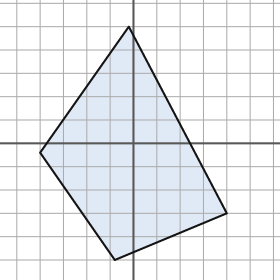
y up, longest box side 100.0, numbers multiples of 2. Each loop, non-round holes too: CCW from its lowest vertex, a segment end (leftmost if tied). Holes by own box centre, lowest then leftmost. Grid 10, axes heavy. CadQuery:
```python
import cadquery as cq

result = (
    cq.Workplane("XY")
    .moveTo(-8.0, -50.0)
    .lineTo(40.0, -30.0)
    .lineTo(-2.0, 50.0)
    .lineTo(-40.0, -4.0)
    .close()
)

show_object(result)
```